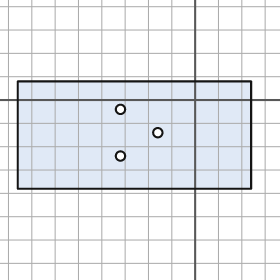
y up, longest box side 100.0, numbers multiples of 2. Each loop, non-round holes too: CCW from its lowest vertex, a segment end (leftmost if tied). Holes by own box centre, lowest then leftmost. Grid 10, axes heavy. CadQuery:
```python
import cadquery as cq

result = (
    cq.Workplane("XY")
    .moveTo(-76.0, -38.0)
    .lineTo(24.0, -38.0)
    .lineTo(24.0, 8.0)
    .lineTo(-76.0, 8.0)
    .close()
    .moveTo(-32.0, -24.0)
    .circle(2.0)
    .moveTo(-16.0, -14.0)
    .circle(2.0)
    .moveTo(-32.0, -4.0)
    .circle(2.0)
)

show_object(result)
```